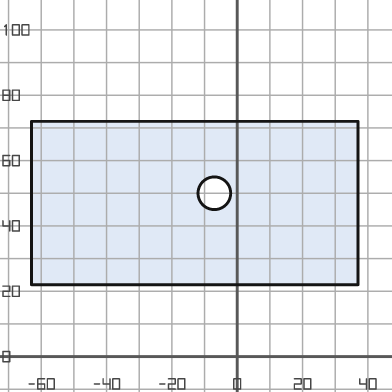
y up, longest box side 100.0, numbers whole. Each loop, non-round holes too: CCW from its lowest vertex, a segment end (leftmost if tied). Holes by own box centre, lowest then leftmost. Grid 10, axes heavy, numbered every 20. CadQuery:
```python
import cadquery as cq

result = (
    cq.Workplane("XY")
    .moveTo(-63.0, 22.0)
    .lineTo(37.0, 22.0)
    .lineTo(37.0, 72.0)
    .lineTo(-63.0, 72.0)
    .close()
    .moveTo(-7.0, 50.0)
    .circle(5.0)
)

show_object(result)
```